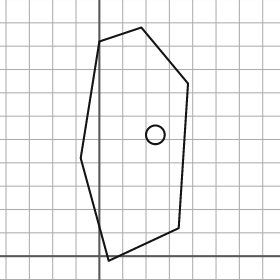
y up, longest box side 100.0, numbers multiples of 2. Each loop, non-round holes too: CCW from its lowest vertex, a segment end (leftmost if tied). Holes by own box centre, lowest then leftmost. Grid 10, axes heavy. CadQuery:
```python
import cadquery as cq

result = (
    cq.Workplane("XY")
    .moveTo(4.0, -2.0)
    .lineTo(34.0, 12.0)
    .lineTo(38.0, 74.0)
    .lineTo(18.0, 98.0)
    .lineTo(0.0, 92.0)
    .lineTo(-8.0, 42.0)
    .close()
    .moveTo(24.0, 52.0)
    .circle(4.0)
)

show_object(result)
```